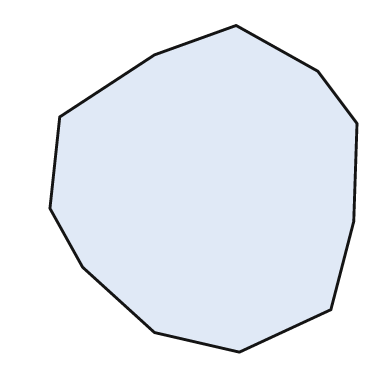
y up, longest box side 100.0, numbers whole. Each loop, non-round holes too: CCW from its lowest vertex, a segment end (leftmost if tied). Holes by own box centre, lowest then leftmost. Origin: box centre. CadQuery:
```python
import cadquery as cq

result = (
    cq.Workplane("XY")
    .moveTo(11.0, -50.0)
    .lineTo(39.0, -37.0)
    .lineTo(46.0, -10.0)
    .lineTo(47.0, 20.0)
    .lineTo(35.0, 36.0)
    .lineTo(10.0, 50.0)
    .lineTo(-15.0, 41.0)
    .lineTo(-44.0, 22.0)
    .lineTo(-47.0, -6.0)
    .lineTo(-37.0, -24.0)
    .lineTo(-15.0, -44.0)
    .close()
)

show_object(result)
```